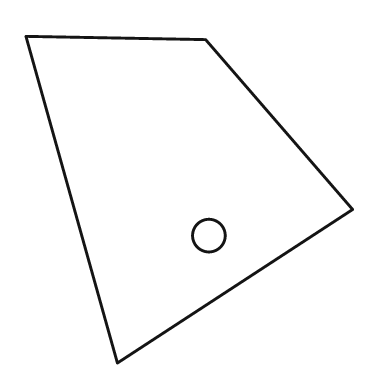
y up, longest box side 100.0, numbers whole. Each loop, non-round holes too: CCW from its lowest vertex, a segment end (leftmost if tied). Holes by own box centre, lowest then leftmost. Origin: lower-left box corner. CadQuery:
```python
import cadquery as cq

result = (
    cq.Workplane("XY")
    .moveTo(28.0, 0.0)
    .lineTo(100.0, 47.0)
    .lineTo(55.0, 99.0)
    .lineTo(0.0, 100.0)
    .close()
    .moveTo(56.0, 39.0)
    .circle(5.0)
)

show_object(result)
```